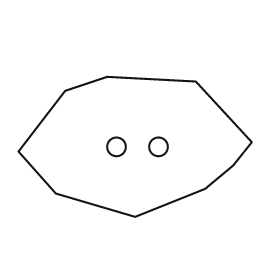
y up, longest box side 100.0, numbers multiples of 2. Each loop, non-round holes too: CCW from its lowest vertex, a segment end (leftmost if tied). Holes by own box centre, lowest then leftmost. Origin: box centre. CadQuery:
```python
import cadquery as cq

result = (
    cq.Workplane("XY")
    .moveTo(0.0, -30.0)
    .lineTo(30.0, -18.0)
    .lineTo(42.0, -8.0)
    .lineTo(50.0, 2.0)
    .lineTo(26.0, 28.0)
    .lineTo(-12.0, 30.0)
    .lineTo(-30.0, 24.0)
    .lineTo(-50.0, -2.0)
    .lineTo(-34.0, -20.0)
    .close()
    .moveTo(-8.0, 0.0)
    .circle(4.0)
    .moveTo(10.0, 0.0)
    .circle(4.0)
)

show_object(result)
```